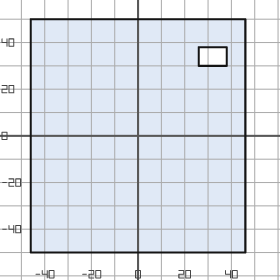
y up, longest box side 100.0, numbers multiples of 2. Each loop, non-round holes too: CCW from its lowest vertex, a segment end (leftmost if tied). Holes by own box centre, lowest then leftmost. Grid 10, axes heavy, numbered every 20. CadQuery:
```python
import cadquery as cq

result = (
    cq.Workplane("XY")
    .moveTo(-46.0, -50.0)
    .lineTo(46.0, -50.0)
    .lineTo(46.0, 50.0)
    .lineTo(-46.0, 50.0)
    .close()
    .moveTo(26.0, 30.0)
    .lineTo(38.0, 30.0)
    .lineTo(38.0, 38.0)
    .lineTo(26.0, 38.0)
    .close()
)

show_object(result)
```